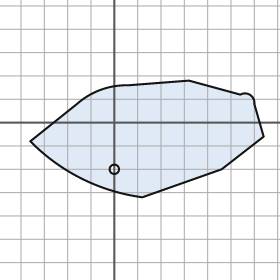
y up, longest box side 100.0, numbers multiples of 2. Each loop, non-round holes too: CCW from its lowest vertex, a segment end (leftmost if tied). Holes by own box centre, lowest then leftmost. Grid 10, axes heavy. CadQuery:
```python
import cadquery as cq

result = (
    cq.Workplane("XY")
    .moveTo(12.0, -32.0)
    .lineTo(46.0, -20.0)
    .lineTo(64.0, -6.0)
    .lineTo(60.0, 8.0)
    .threePointArc((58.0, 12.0), (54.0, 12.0))
    .lineTo(32.0, 18.0)
    .lineTo(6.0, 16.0)
    .threePointArc((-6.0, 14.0), (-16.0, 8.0))
    .lineTo(-36.0, -8.0)
    .threePointArc((-14.0, -24.0), (12.0, -32.0))
    .close()
    .moveTo(0.0, -20.0)
    .circle(2.0)
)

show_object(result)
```